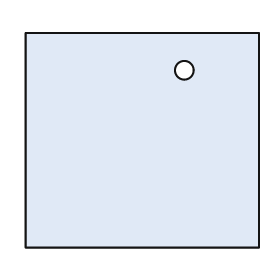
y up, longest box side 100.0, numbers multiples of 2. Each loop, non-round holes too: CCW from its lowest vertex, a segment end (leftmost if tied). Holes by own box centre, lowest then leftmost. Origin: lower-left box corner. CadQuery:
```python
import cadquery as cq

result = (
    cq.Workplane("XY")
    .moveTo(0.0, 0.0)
    .lineTo(100.0, 0.0)
    .lineTo(100.0, 92.0)
    .lineTo(0.0, 92.0)
    .close()
    .moveTo(68.0, 76.0)
    .circle(4.0)
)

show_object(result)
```